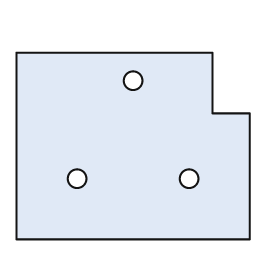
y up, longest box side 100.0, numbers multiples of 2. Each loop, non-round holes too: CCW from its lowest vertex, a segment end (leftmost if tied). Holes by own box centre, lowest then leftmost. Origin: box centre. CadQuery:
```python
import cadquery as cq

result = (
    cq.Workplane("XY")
    .moveTo(-50.0, -40.0)
    .lineTo(50.0, -40.0)
    .lineTo(50.0, 14.0)
    .lineTo(34.0, 14.0)
    .lineTo(34.0, 40.0)
    .lineTo(-50.0, 40.0)
    .close()
    .moveTo(-24.0, -14.0)
    .circle(4.0)
    .moveTo(24.0, -14.0)
    .circle(4.0)
    .moveTo(0.0, 28.0)
    .circle(4.0)
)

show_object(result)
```